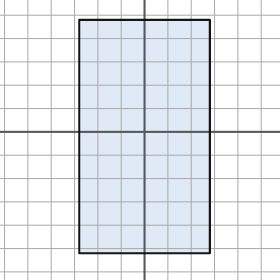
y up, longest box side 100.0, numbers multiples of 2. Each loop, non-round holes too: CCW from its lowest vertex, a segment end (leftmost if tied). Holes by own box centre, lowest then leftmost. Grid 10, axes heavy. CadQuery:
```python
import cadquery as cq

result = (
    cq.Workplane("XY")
    .moveTo(-28.0, -52.0)
    .lineTo(28.0, -52.0)
    .lineTo(28.0, 48.0)
    .lineTo(-28.0, 48.0)
    .close()
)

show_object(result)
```